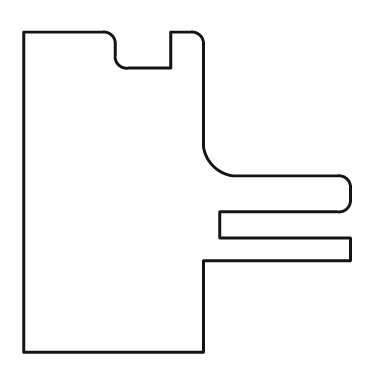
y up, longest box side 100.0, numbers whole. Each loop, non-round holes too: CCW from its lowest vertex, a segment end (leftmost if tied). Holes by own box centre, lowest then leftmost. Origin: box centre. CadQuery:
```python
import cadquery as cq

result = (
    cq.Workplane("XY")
    .moveTo(-50.0, -49.0)
    .lineTo(5.0, -49.0)
    .lineTo(5.0, -21.0)
    .lineTo(50.0, -21.0)
    .lineTo(50.0, -14.0)
    .lineTo(10.0, -14.0)
    .lineTo(10.0, -6.0)
    .lineTo(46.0, -6.0)
    .threePointArc((49.0, -5.0), (50.0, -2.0))
    .lineTo(50.0, 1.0)
    .threePointArc((49.0, 4.0), (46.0, 5.0))
    .lineTo(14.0, 5.0)
    .threePointArc((8.0, 8.0), (5.0, 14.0))
    .lineTo(5.0, 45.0)
    .threePointArc((4.0, 48.0), (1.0, 49.0))
    .lineTo(-5.0, 49.0)
    .lineTo(-5.0, 38.0)
    .lineTo(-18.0, 38.0)
    .threePointArc((-21.0, 39.0), (-22.0, 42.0))
    .lineTo(-22.0, 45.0)
    .threePointArc((-23.0, 48.0), (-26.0, 49.0))
    .lineTo(-50.0, 49.0)
    .close()
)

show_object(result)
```